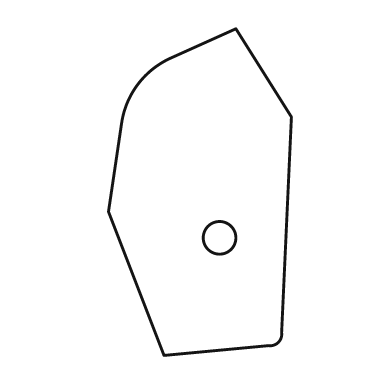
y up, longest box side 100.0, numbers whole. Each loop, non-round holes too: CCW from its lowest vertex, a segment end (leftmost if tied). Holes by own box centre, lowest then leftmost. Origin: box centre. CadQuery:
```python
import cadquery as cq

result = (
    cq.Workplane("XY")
    .moveTo(-11.0, -50.0)
    .lineTo(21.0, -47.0)
    .threePointArc((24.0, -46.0), (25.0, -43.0))
    .lineTo(28.0, 23.0)
    .lineTo(11.0, 50.0)
    .lineTo(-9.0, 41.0)
    .threePointArc((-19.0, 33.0), (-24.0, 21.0))
    .lineTo(-28.0, -6.0)
    .close()
    .moveTo(6.0, -14.0)
    .circle(5.0)
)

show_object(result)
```